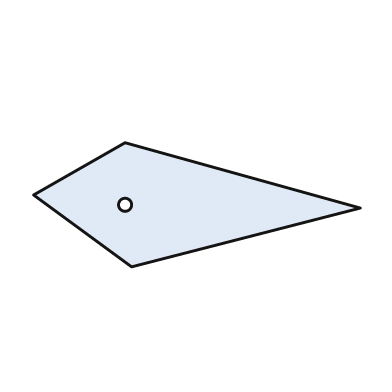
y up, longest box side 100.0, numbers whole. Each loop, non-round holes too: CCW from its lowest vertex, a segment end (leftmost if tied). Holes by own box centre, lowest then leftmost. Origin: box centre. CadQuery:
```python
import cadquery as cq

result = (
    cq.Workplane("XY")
    .moveTo(-20.0, -19.0)
    .lineTo(50.0, -1.0)
    .lineTo(-22.0, 19.0)
    .lineTo(-50.0, 3.0)
    .close()
    .moveTo(-22.0, 0.0)
    .circle(2.0)
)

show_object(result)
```